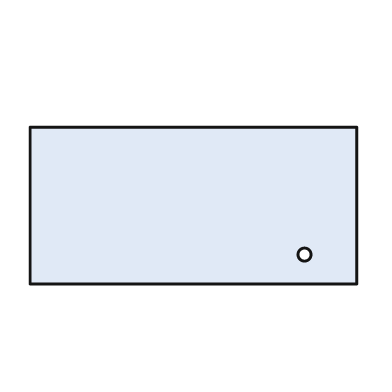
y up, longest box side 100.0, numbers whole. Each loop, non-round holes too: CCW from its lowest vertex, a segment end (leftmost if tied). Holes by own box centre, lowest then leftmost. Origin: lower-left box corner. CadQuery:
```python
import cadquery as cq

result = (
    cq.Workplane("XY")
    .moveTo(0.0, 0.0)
    .lineTo(100.0, 0.0)
    .lineTo(100.0, 48.0)
    .lineTo(0.0, 48.0)
    .close()
    .moveTo(84.0, 9.0)
    .circle(2.0)
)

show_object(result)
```